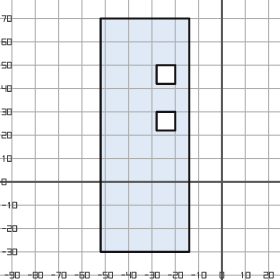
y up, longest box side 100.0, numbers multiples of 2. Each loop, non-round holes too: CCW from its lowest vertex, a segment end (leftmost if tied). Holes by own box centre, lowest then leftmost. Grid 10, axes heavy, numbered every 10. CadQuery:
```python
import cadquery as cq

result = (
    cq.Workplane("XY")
    .moveTo(-52.0, -30.0)
    .lineTo(-14.0, -30.0)
    .lineTo(-14.0, 70.0)
    .lineTo(-52.0, 70.0)
    .close()
    .moveTo(-28.0, 22.0)
    .lineTo(-20.0, 22.0)
    .lineTo(-20.0, 30.0)
    .lineTo(-28.0, 30.0)
    .close()
    .moveTo(-28.0, 42.0)
    .lineTo(-20.0, 42.0)
    .lineTo(-20.0, 50.0)
    .lineTo(-28.0, 50.0)
    .close()
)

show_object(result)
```